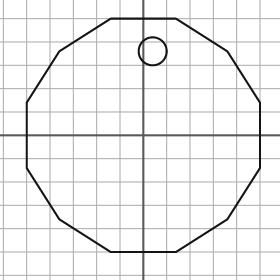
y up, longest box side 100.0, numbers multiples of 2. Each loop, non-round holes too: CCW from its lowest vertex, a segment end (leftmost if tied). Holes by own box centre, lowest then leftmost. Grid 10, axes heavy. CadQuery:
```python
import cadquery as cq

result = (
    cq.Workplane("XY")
    .moveTo(-14.0, -50.0)
    .lineTo(14.0, -50.0)
    .lineTo(36.0, -36.0)
    .lineTo(50.0, -14.0)
    .lineTo(50.0, 14.0)
    .lineTo(36.0, 36.0)
    .lineTo(14.0, 50.0)
    .lineTo(-14.0, 50.0)
    .lineTo(-36.0, 36.0)
    .lineTo(-50.0, 14.0)
    .lineTo(-50.0, -14.0)
    .lineTo(-36.0, -36.0)
    .close()
    .moveTo(4.0, 36.0)
    .circle(6.0)
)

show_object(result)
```